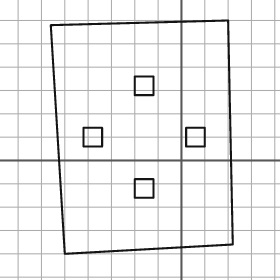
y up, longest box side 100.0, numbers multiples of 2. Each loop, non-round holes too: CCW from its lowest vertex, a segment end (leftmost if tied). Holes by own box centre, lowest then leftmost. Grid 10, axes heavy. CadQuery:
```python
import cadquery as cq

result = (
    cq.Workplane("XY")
    .moveTo(-50.0, -40.0)
    .lineTo(22.0, -36.0)
    .lineTo(20.0, 60.0)
    .lineTo(-56.0, 58.0)
    .close()
    .moveTo(-20.0, -16.0)
    .lineTo(-12.0, -16.0)
    .lineTo(-12.0, -8.0)
    .lineTo(-20.0, -8.0)
    .close()
    .moveTo(-42.0, 6.0)
    .lineTo(-34.0, 6.0)
    .lineTo(-34.0, 14.0)
    .lineTo(-42.0, 14.0)
    .close()
    .moveTo(2.0, 6.0)
    .lineTo(10.0, 6.0)
    .lineTo(10.0, 14.0)
    .lineTo(2.0, 14.0)
    .close()
    .moveTo(-20.0, 28.0)
    .lineTo(-12.0, 28.0)
    .lineTo(-12.0, 36.0)
    .lineTo(-20.0, 36.0)
    .close()
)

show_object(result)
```